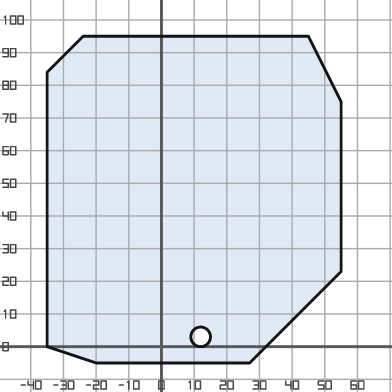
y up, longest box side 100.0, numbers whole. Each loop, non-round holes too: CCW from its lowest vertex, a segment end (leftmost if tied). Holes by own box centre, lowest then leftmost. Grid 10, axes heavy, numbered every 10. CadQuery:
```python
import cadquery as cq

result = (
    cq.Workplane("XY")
    .moveTo(-20.0, -5.0)
    .lineTo(27.0, -5.0)
    .lineTo(55.0, 23.0)
    .lineTo(55.0, 75.0)
    .lineTo(45.0, 95.0)
    .lineTo(-24.0, 95.0)
    .lineTo(-35.0, 84.0)
    .lineTo(-35.0, 0.0)
    .close()
    .moveTo(12.0, 3.0)
    .circle(3.0)
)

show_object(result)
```